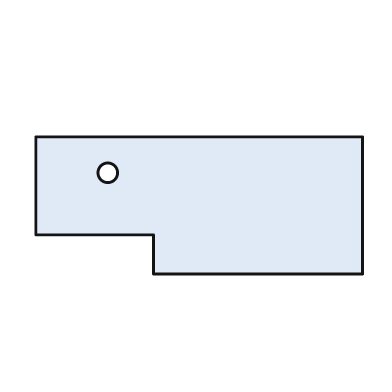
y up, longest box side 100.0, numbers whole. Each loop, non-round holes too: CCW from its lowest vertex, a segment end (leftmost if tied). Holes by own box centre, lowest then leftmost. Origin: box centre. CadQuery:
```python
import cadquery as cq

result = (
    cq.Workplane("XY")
    .moveTo(-14.0, -21.0)
    .lineTo(50.0, -21.0)
    .lineTo(50.0, 21.0)
    .lineTo(-50.0, 21.0)
    .lineTo(-50.0, -9.0)
    .lineTo(-14.0, -9.0)
    .close()
    .moveTo(-28.0, 10.0)
    .circle(3.0)
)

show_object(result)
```